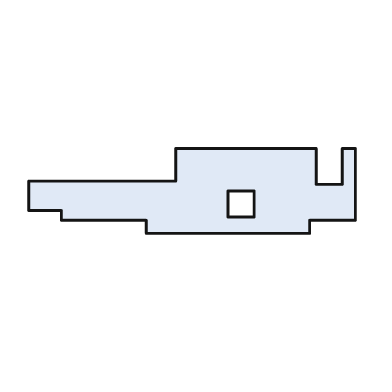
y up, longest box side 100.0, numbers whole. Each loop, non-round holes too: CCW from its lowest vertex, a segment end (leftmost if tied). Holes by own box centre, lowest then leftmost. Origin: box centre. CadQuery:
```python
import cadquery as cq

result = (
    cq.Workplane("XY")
    .moveTo(-14.0, -13.0)
    .lineTo(36.0, -13.0)
    .lineTo(36.0, -9.0)
    .lineTo(50.0, -9.0)
    .lineTo(50.0, 13.0)
    .lineTo(46.0, 13.0)
    .lineTo(46.0, 2.0)
    .lineTo(38.0, 2.0)
    .lineTo(38.0, 13.0)
    .lineTo(-5.0, 13.0)
    .lineTo(-5.0, 3.0)
    .lineTo(-50.0, 3.0)
    .lineTo(-50.0, -6.0)
    .lineTo(-40.0, -6.0)
    .lineTo(-40.0, -9.0)
    .lineTo(-14.0, -9.0)
    .close()
    .moveTo(11.0, -8.0)
    .lineTo(19.0, -8.0)
    .lineTo(19.0, 0.0)
    .lineTo(11.0, 0.0)
    .close()
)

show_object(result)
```